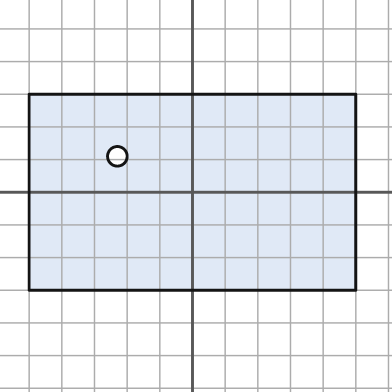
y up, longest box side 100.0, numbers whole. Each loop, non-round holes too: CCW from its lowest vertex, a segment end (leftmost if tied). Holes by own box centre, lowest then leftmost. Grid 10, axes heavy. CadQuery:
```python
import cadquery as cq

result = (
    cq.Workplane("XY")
    .moveTo(-50.0, -30.0)
    .lineTo(50.0, -30.0)
    .lineTo(50.0, 30.0)
    .lineTo(-50.0, 30.0)
    .close()
    .moveTo(-23.0, 11.0)
    .circle(3.0)
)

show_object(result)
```